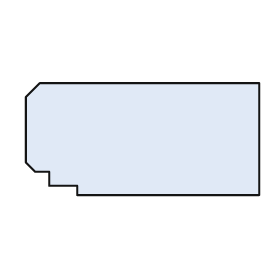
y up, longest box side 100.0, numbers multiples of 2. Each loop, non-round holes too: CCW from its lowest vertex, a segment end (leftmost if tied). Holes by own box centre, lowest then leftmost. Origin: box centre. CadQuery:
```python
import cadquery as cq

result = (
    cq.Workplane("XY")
    .moveTo(-28.0, -24.0)
    .lineTo(50.0, -24.0)
    .lineTo(50.0, 24.0)
    .lineTo(-44.0, 24.0)
    .lineTo(-50.0, 18.0)
    .lineTo(-50.0, -10.0)
    .lineTo(-46.0, -14.0)
    .lineTo(-40.0, -14.0)
    .lineTo(-40.0, -20.0)
    .lineTo(-28.0, -20.0)
    .close()
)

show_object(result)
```